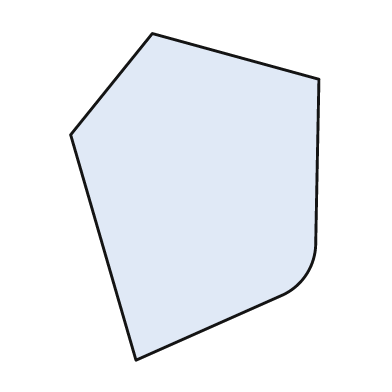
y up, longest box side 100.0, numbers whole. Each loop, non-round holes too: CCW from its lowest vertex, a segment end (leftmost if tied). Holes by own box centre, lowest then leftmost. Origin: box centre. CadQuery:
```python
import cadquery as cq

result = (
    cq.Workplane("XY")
    .moveTo(-18.0, -50.0)
    .lineTo(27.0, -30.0)
    .threePointArc((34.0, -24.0), (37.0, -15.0))
    .lineTo(38.0, 36.0)
    .lineTo(-13.0, 50.0)
    .lineTo(-38.0, 19.0)
    .close()
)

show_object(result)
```